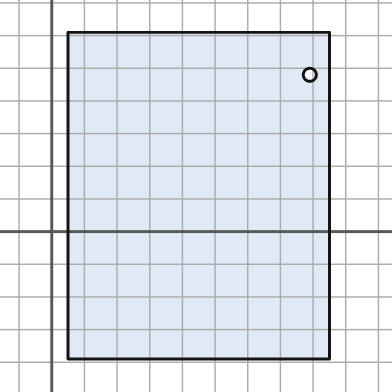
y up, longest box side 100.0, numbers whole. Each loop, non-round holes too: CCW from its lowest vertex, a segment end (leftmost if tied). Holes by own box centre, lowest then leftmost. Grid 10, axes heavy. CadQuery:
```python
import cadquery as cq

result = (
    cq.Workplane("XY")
    .moveTo(5.0, -39.0)
    .lineTo(85.0, -39.0)
    .lineTo(85.0, 61.0)
    .lineTo(5.0, 61.0)
    .close()
    .moveTo(79.0, 48.0)
    .circle(2.0)
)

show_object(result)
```